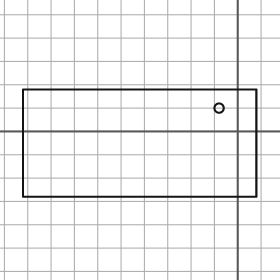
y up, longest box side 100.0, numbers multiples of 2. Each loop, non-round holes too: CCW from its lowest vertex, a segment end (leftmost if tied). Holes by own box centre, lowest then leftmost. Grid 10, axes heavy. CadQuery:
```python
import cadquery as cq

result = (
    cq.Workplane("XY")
    .moveTo(-92.0, -28.0)
    .lineTo(8.0, -28.0)
    .lineTo(8.0, 18.0)
    .lineTo(-92.0, 18.0)
    .close()
    .moveTo(-8.0, 10.0)
    .circle(2.0)
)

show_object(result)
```